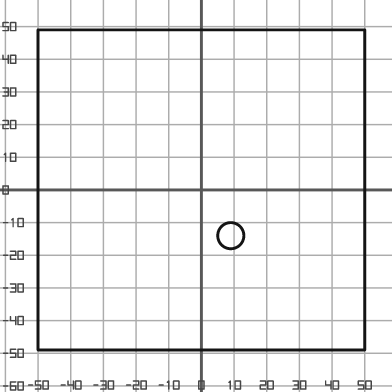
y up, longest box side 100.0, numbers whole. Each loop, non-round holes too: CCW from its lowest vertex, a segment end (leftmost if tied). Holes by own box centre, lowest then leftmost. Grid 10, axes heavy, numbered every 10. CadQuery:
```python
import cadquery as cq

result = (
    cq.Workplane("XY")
    .moveTo(-50.0, -49.0)
    .lineTo(50.0, -49.0)
    .lineTo(50.0, 49.0)
    .lineTo(-50.0, 49.0)
    .close()
    .moveTo(9.0, -14.0)
    .circle(4.0)
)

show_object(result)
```